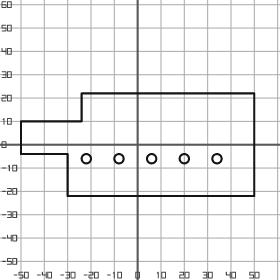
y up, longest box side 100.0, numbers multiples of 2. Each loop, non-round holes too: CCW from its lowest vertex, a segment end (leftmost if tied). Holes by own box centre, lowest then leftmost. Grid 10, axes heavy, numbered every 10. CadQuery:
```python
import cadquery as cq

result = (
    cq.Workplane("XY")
    .moveTo(-30.0, -22.0)
    .lineTo(50.0, -22.0)
    .lineTo(50.0, 22.0)
    .lineTo(-24.0, 22.0)
    .lineTo(-24.0, 10.0)
    .lineTo(-50.0, 10.0)
    .lineTo(-50.0, -4.0)
    .lineTo(-30.0, -4.0)
    .close()
    .moveTo(-22.0, -6.0)
    .circle(2.0)
    .moveTo(-8.0, -6.0)
    .circle(2.0)
    .moveTo(6.0, -6.0)
    .circle(2.0)
    .moveTo(20.0, -6.0)
    .circle(2.0)
    .moveTo(34.0, -6.0)
    .circle(2.0)
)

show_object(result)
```